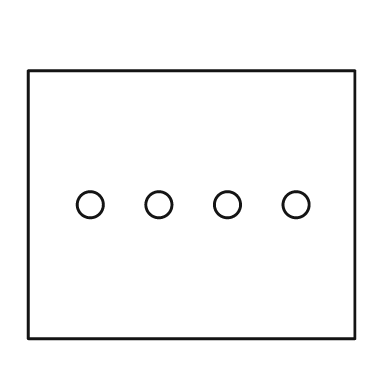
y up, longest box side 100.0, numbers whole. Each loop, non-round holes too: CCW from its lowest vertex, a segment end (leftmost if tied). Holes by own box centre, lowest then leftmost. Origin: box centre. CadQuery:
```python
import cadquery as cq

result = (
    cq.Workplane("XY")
    .moveTo(-50.0, -41.0)
    .lineTo(50.0, -41.0)
    .lineTo(50.0, 41.0)
    .lineTo(-50.0, 41.0)
    .close()
    .moveTo(-31.0, 0.0)
    .circle(4.0)
    .moveTo(-10.0, 0.0)
    .circle(4.0)
    .moveTo(11.0, 0.0)
    .circle(4.0)
    .moveTo(32.0, 0.0)
    .circle(4.0)
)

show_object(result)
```